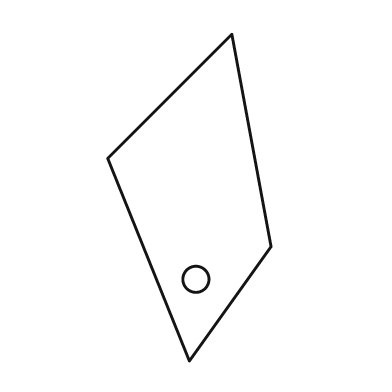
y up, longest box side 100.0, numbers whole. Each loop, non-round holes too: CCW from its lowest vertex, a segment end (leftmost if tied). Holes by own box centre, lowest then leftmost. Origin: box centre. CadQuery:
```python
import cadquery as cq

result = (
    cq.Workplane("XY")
    .moveTo(0.0, -50.0)
    .lineTo(25.0, -15.0)
    .lineTo(13.0, 50.0)
    .lineTo(-25.0, 12.0)
    .close()
    .moveTo(2.0, -25.0)
    .circle(4.0)
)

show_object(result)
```